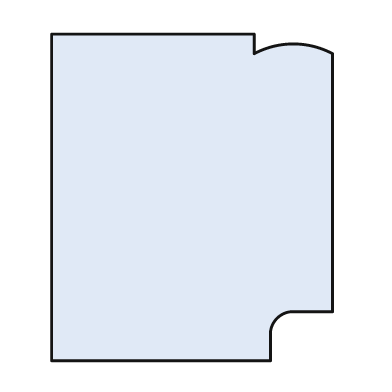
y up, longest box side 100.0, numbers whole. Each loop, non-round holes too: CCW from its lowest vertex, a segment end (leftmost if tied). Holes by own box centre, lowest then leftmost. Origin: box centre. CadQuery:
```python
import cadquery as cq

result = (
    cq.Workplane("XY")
    .moveTo(-43.0, -50.0)
    .lineTo(24.0, -50.0)
    .lineTo(24.0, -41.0)
    .threePointArc((26.0, -37.0), (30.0, -35.0))
    .lineTo(43.0, -35.0)
    .lineTo(43.0, 44.0)
    .threePointArc((31.0, 47.0), (19.0, 44.0))
    .lineTo(19.0, 50.0)
    .lineTo(-43.0, 50.0)
    .close()
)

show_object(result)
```